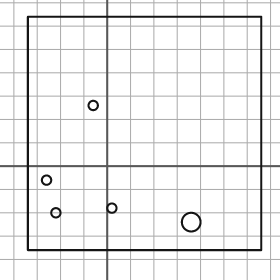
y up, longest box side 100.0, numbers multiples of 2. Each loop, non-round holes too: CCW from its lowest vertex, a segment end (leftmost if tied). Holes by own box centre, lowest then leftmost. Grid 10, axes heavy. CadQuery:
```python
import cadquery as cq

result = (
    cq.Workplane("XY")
    .moveTo(-34.0, -36.0)
    .lineTo(66.0, -36.0)
    .lineTo(66.0, 64.0)
    .lineTo(-34.0, 64.0)
    .close()
    .moveTo(36.0, -24.0)
    .circle(4.0)
    .moveTo(-22.0, -20.0)
    .circle(2.0)
    .moveTo(2.0, -18.0)
    .circle(2.0)
    .moveTo(-26.0, -6.0)
    .circle(2.0)
    .moveTo(-6.0, 26.0)
    .circle(2.0)
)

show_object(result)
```